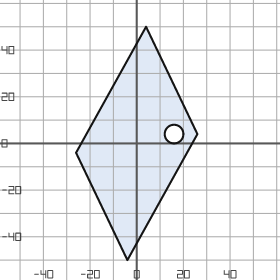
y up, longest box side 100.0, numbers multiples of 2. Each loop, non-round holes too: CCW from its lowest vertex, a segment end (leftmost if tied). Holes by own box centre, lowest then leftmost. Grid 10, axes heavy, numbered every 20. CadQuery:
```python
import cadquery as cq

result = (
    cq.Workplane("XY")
    .moveTo(-4.0, -50.0)
    .lineTo(26.0, 4.0)
    .lineTo(4.0, 50.0)
    .lineTo(-26.0, -4.0)
    .close()
    .moveTo(16.0, 4.0)
    .circle(4.0)
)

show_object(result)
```